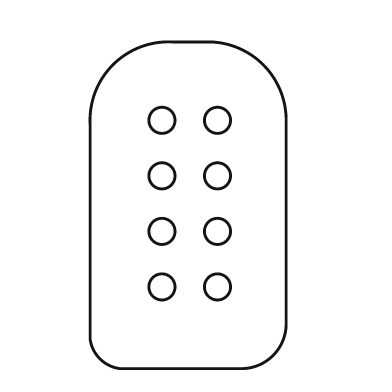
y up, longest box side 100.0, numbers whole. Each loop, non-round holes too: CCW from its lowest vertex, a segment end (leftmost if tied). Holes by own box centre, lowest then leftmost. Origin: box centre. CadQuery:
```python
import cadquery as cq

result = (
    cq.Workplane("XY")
    .moveTo(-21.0, -50.0)
    .lineTo(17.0, -50.0)
    .threePointArc((26.0, -46.0), (30.0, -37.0))
    .lineTo(30.0, 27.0)
    .threePointArc((23.0, 43.0), (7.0, 50.0))
    .lineTo(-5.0, 50.0)
    .threePointArc((-23.0, 43.0), (-30.0, 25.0))
    .lineTo(-30.0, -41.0)
    .threePointArc((-27.0, -47.0), (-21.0, -50.0))
    .close()
    .moveTo(-8.0, -25.0)
    .circle(4.0)
    .moveTo(9.0, -25.0)
    .circle(4.0)
    .moveTo(-8.0, -8.0)
    .circle(4.0)
    .moveTo(9.0, -8.0)
    .circle(4.0)
    .moveTo(-8.0, 9.0)
    .circle(4.0)
    .moveTo(9.0, 9.0)
    .circle(4.0)
    .moveTo(-8.0, 26.0)
    .circle(4.0)
    .moveTo(9.0, 26.0)
    .circle(4.0)
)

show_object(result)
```